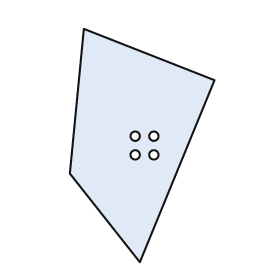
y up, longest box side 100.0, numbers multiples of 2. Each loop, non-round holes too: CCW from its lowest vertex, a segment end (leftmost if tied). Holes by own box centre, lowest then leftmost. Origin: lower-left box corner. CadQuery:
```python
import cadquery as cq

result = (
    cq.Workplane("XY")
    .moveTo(30.0, 0.0)
    .lineTo(62.0, 78.0)
    .lineTo(6.0, 100.0)
    .lineTo(0.0, 38.0)
    .close()
    .moveTo(28.0, 46.0)
    .circle(2.0)
    .moveTo(36.0, 46.0)
    .circle(2.0)
    .moveTo(28.0, 54.0)
    .circle(2.0)
    .moveTo(36.0, 54.0)
    .circle(2.0)
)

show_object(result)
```